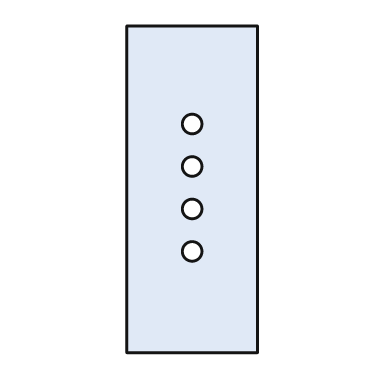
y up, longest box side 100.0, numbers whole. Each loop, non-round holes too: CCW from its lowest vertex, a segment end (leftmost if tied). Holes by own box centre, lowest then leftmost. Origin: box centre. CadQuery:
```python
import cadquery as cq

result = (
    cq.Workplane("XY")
    .moveTo(-20.0, -50.0)
    .lineTo(20.0, -50.0)
    .lineTo(20.0, 50.0)
    .lineTo(-20.0, 50.0)
    .close()
    .moveTo(0.0, -19.0)
    .circle(3.0)
    .moveTo(0.0, -6.0)
    .circle(3.0)
    .moveTo(0.0, 7.0)
    .circle(3.0)
    .moveTo(0.0, 20.0)
    .circle(3.0)
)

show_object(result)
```